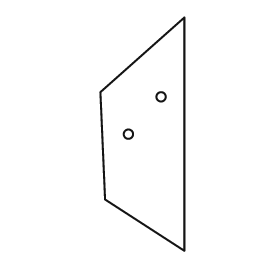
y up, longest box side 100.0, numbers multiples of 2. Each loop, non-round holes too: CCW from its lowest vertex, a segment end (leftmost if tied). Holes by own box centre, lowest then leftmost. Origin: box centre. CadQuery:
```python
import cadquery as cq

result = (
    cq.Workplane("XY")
    .moveTo(18.0, -50.0)
    .lineTo(18.0, 50.0)
    .lineTo(-18.0, 18.0)
    .lineTo(-16.0, -28.0)
    .close()
    .moveTo(-6.0, 0.0)
    .circle(2.0)
    .moveTo(8.0, 16.0)
    .circle(2.0)
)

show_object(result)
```